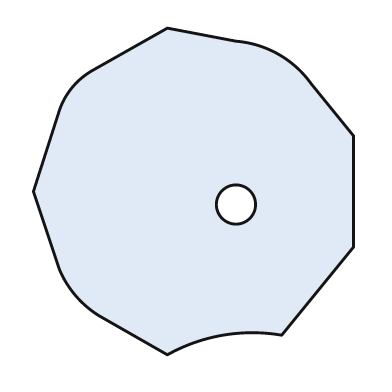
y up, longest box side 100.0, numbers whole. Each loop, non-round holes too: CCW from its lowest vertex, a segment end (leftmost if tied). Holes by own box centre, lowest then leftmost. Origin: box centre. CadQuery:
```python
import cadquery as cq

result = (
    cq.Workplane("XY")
    .moveTo(-8.0, -50.0)
    .threePointArc((9.0, -44.0), (27.0, -44.0))
    .lineTo(49.0, -17.0)
    .lineTo(49.0, 17.0)
    .lineTo(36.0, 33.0)
    .threePointArc((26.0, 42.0), (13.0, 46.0))
    .lineTo(-8.0, 50.0)
    .lineTo(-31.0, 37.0)
    .threePointArc((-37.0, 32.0), (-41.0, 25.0))
    .lineTo(-49.0, 0.0)
    .lineTo(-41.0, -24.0)
    .threePointArc((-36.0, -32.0), (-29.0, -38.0))
    .close()
    .moveTo(13.0, -4.0)
    .circle(6.0)
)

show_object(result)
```